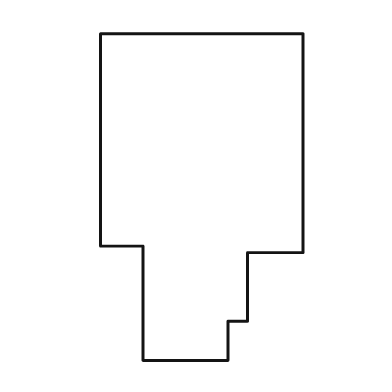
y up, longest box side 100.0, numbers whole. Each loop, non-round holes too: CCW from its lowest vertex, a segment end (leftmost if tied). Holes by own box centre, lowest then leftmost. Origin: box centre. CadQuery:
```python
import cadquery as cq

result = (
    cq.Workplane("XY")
    .moveTo(-18.0, -50.0)
    .lineTo(8.0, -50.0)
    .lineTo(8.0, -38.0)
    .lineTo(14.0, -38.0)
    .lineTo(14.0, -17.0)
    .lineTo(31.0, -17.0)
    .lineTo(31.0, 50.0)
    .lineTo(-31.0, 50.0)
    .lineTo(-31.0, -15.0)
    .lineTo(-18.0, -15.0)
    .close()
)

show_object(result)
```